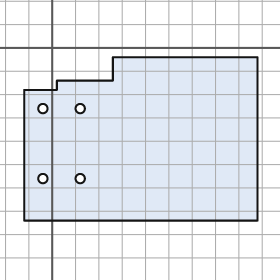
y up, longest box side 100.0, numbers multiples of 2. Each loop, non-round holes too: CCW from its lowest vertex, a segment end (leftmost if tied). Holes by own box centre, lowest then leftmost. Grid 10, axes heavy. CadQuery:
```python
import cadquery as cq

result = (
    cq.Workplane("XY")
    .moveTo(-12.0, -74.0)
    .lineTo(88.0, -74.0)
    .lineTo(88.0, -4.0)
    .lineTo(26.0, -4.0)
    .lineTo(26.0, -14.0)
    .lineTo(2.0, -14.0)
    .lineTo(2.0, -18.0)
    .lineTo(-12.0, -18.0)
    .close()
    .moveTo(-4.0, -56.0)
    .circle(2.0)
    .moveTo(12.0, -56.0)
    .circle(2.0)
    .moveTo(-4.0, -26.0)
    .circle(2.0)
    .moveTo(12.0, -26.0)
    .circle(2.0)
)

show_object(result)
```